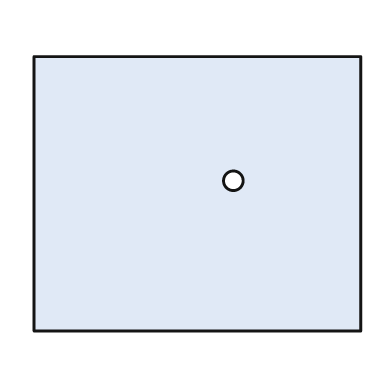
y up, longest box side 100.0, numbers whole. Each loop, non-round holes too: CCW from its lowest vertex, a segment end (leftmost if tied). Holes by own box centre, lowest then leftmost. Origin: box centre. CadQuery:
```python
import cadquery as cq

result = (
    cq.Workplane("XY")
    .moveTo(-50.0, -42.0)
    .lineTo(50.0, -42.0)
    .lineTo(50.0, 42.0)
    .lineTo(-50.0, 42.0)
    .close()
    .moveTo(11.0, 4.0)
    .circle(3.0)
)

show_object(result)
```